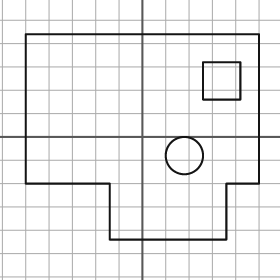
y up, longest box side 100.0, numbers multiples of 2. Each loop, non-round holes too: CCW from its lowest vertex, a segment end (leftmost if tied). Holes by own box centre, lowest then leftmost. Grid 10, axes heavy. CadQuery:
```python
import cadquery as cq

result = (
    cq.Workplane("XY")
    .moveTo(-14.0, -44.0)
    .lineTo(36.0, -44.0)
    .lineTo(36.0, -20.0)
    .lineTo(50.0, -20.0)
    .lineTo(50.0, 44.0)
    .lineTo(-50.0, 44.0)
    .lineTo(-50.0, -20.0)
    .lineTo(-14.0, -20.0)
    .close()
    .moveTo(18.0, -8.0)
    .circle(8.0)
    .moveTo(26.0, 16.0)
    .lineTo(42.0, 16.0)
    .lineTo(42.0, 32.0)
    .lineTo(26.0, 32.0)
    .close()
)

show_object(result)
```